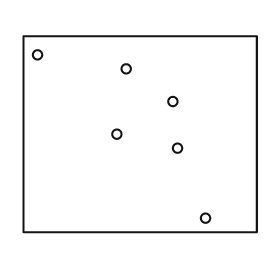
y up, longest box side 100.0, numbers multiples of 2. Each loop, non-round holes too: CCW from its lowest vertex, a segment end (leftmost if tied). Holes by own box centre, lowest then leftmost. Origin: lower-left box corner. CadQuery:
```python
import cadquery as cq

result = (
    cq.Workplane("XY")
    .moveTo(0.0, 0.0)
    .lineTo(100.0, 0.0)
    .lineTo(100.0, 84.0)
    .lineTo(0.0, 84.0)
    .close()
    .moveTo(78.0, 6.0)
    .circle(2.0)
    .moveTo(66.0, 36.0)
    .circle(2.0)
    .moveTo(40.0, 42.0)
    .circle(2.0)
    .moveTo(64.0, 56.0)
    .circle(2.0)
    .moveTo(44.0, 70.0)
    .circle(2.0)
    .moveTo(6.0, 76.0)
    .circle(2.0)
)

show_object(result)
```